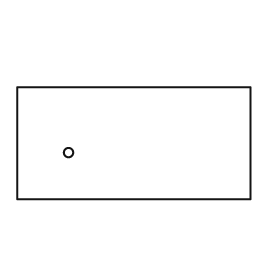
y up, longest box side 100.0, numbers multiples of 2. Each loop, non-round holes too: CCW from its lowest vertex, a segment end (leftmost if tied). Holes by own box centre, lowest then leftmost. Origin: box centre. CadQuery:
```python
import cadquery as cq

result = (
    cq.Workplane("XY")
    .moveTo(-50.0, -24.0)
    .lineTo(50.0, -24.0)
    .lineTo(50.0, 24.0)
    .lineTo(-50.0, 24.0)
    .close()
    .moveTo(-28.0, -4.0)
    .circle(2.0)
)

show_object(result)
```